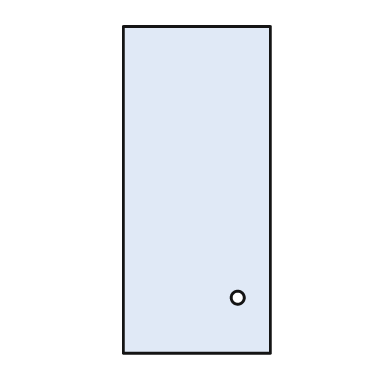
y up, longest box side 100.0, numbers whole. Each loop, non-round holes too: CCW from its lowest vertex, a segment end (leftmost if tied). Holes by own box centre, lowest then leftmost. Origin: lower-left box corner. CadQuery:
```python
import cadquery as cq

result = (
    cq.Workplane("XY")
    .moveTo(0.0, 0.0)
    .lineTo(45.0, 0.0)
    .lineTo(45.0, 100.0)
    .lineTo(0.0, 100.0)
    .close()
    .moveTo(35.0, 17.0)
    .circle(2.0)
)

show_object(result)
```